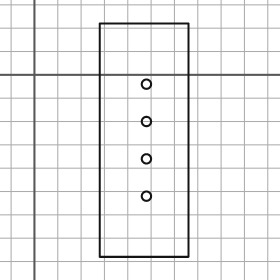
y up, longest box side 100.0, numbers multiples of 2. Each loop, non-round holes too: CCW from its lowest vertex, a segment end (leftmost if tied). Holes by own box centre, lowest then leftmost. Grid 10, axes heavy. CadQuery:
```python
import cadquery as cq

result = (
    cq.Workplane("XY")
    .moveTo(28.0, -78.0)
    .lineTo(66.0, -78.0)
    .lineTo(66.0, 22.0)
    .lineTo(28.0, 22.0)
    .close()
    .moveTo(48.0, -52.0)
    .circle(2.0)
    .moveTo(48.0, -36.0)
    .circle(2.0)
    .moveTo(48.0, -20.0)
    .circle(2.0)
    .moveTo(48.0, -4.0)
    .circle(2.0)
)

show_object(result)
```